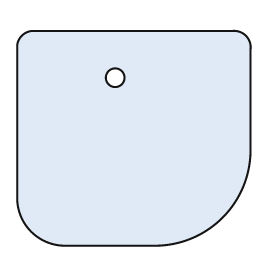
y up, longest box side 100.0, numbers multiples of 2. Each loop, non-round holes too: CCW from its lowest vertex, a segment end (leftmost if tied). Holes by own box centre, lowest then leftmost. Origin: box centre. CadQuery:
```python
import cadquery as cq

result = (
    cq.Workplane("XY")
    .moveTo(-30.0, -46.0)
    .lineTo(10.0, -46.0)
    .threePointArc((38.0, -34.0), (50.0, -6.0))
    .lineTo(50.0, 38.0)
    .threePointArc((48.0, 44.0), (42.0, 46.0))
    .lineTo(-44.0, 46.0)
    .threePointArc((-48.0, 44.0), (-50.0, 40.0))
    .lineTo(-50.0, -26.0)
    .threePointArc((-44.0, -40.0), (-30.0, -46.0))
    .close()
    .moveTo(-8.0, 26.0)
    .circle(4.0)
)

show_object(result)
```